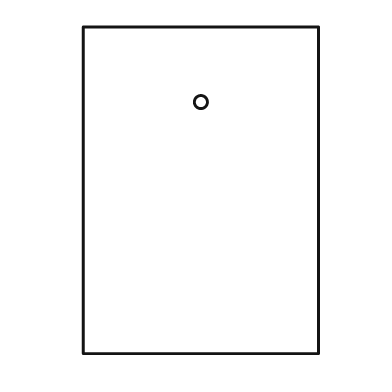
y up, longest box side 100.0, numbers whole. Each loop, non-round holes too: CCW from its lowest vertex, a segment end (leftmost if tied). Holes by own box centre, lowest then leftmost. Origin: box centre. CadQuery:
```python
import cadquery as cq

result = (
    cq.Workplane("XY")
    .moveTo(-36.0, -50.0)
    .lineTo(36.0, -50.0)
    .lineTo(36.0, 50.0)
    .lineTo(-36.0, 50.0)
    .close()
    .moveTo(0.0, 27.0)
    .circle(2.0)
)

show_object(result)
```